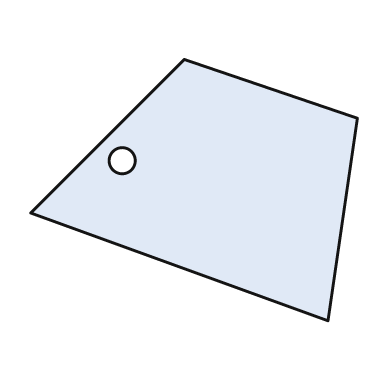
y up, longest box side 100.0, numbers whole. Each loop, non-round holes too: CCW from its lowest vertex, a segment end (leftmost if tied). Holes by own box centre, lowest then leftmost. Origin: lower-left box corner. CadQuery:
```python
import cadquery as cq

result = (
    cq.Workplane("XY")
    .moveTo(91.0, 0.0)
    .lineTo(100.0, 62.0)
    .lineTo(47.0, 80.0)
    .lineTo(0.0, 33.0)
    .close()
    .moveTo(28.0, 49.0)
    .circle(4.0)
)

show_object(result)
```